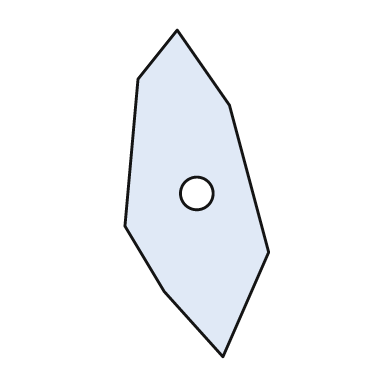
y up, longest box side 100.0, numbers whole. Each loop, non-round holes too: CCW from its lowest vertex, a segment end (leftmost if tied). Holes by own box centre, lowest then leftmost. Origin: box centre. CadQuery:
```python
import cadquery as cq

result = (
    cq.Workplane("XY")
    .moveTo(8.0, -50.0)
    .lineTo(22.0, -18.0)
    .lineTo(10.0, 27.0)
    .lineTo(-6.0, 50.0)
    .lineTo(-18.0, 35.0)
    .lineTo(-22.0, -10.0)
    .lineTo(-10.0, -30.0)
    .close()
    .moveTo(0.0, 0.0)
    .circle(5.0)
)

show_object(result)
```